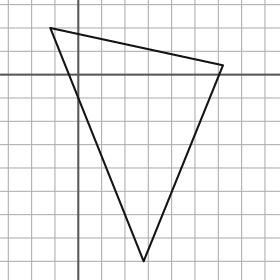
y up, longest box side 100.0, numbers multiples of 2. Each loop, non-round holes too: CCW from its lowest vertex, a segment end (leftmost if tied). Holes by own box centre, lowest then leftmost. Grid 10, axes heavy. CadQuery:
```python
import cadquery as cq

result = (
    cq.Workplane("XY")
    .moveTo(28.0, -80.0)
    .lineTo(62.0, 4.0)
    .lineTo(-12.0, 20.0)
    .close()
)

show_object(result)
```